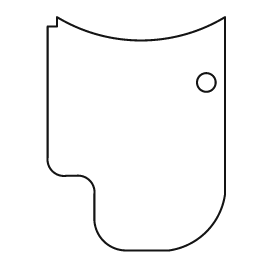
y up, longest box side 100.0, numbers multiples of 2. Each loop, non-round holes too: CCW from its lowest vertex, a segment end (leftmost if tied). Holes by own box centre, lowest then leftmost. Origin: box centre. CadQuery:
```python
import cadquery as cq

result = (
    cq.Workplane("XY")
    .moveTo(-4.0, -50.0)
    .lineTo(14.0, -50.0)
    .threePointArc((30.0, -42.0), (38.0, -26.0))
    .lineTo(38.0, 50.0)
    .threePointArc((2.0, 40.0), (-34.0, 50.0))
    .lineTo(-34.0, 46.0)
    .lineTo(-38.0, 46.0)
    .lineTo(-38.0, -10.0)
    .threePointArc((-36.0, -16.0), (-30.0, -18.0))
    .lineTo(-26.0, -18.0)
    .threePointArc((-20.0, -20.0), (-18.0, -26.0))
    .lineTo(-18.0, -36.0)
    .threePointArc((-14.0, -46.0), (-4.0, -50.0))
    .close()
    .moveTo(30.0, 22.0)
    .circle(4.0)
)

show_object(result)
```